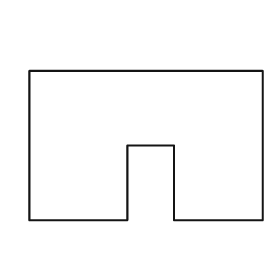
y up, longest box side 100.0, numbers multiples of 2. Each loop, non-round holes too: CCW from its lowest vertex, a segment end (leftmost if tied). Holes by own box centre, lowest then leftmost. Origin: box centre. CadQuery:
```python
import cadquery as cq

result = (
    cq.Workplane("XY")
    .moveTo(-50.0, -32.0)
    .lineTo(-8.0, -32.0)
    .lineTo(-8.0, 0.0)
    .lineTo(12.0, 0.0)
    .lineTo(12.0, -32.0)
    .lineTo(50.0, -32.0)
    .lineTo(50.0, 32.0)
    .lineTo(-50.0, 32.0)
    .close()
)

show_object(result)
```